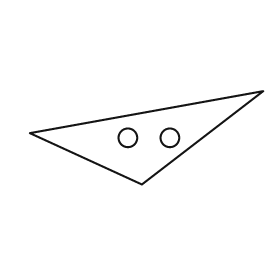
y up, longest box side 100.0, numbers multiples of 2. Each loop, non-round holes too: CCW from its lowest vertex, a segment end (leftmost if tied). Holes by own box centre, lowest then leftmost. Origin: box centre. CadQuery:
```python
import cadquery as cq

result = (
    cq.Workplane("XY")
    .moveTo(-2.0, -20.0)
    .lineTo(50.0, 20.0)
    .lineTo(-50.0, 2.0)
    .close()
    .moveTo(-8.0, 0.0)
    .circle(4.0)
    .moveTo(10.0, 0.0)
    .circle(4.0)
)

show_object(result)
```